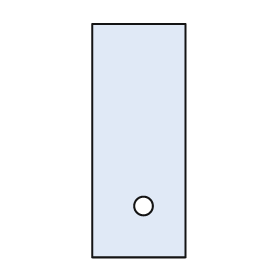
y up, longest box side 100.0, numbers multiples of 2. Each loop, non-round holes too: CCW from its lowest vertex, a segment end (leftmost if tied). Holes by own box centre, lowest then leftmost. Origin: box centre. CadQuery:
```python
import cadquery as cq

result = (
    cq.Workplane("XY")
    .moveTo(-20.0, -50.0)
    .lineTo(20.0, -50.0)
    .lineTo(20.0, 50.0)
    .lineTo(-20.0, 50.0)
    .close()
    .moveTo(2.0, -28.0)
    .circle(4.0)
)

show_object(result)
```